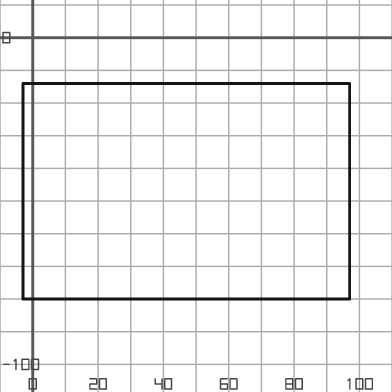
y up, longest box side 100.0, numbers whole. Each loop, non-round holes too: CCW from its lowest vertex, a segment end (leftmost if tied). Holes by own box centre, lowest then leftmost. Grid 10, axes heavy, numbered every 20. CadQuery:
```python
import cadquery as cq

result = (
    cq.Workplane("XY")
    .moveTo(-3.0, -80.0)
    .lineTo(97.0, -80.0)
    .lineTo(97.0, -14.0)
    .lineTo(-3.0, -14.0)
    .close()
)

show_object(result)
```